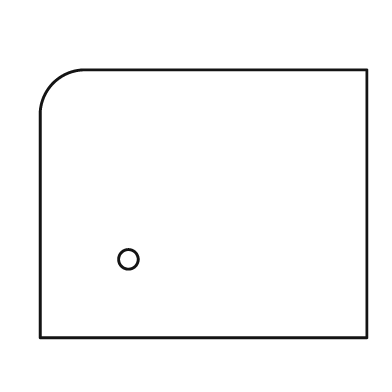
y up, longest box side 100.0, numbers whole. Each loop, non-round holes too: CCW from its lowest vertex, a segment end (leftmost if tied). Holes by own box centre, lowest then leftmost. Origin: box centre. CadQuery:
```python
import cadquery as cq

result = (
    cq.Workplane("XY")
    .moveTo(-50.0, -41.0)
    .lineTo(50.0, -41.0)
    .lineTo(50.0, 41.0)
    .lineTo(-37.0, 41.0)
    .threePointArc((-46.0, 37.0), (-50.0, 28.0))
    .close()
    .moveTo(-23.0, -17.0)
    .circle(3.0)
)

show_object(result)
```